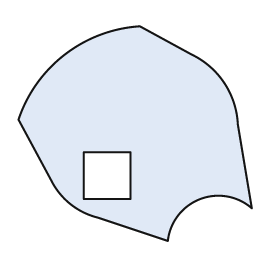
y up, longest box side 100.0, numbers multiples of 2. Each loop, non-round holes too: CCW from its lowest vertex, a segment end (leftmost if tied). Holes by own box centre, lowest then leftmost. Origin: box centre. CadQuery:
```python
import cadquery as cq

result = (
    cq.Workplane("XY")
    .moveTo(14.0, -46.0)
    .threePointArc((28.0, -28.0), (50.0, -32.0))
    .lineTo(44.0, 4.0)
    .threePointArc((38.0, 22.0), (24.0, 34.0))
    .lineTo(2.0, 46.0)
    .threePointArc((-30.0, 34.0), (-50.0, 6.0))
    .lineTo(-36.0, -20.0)
    .threePointArc((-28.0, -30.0), (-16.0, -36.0))
    .close()
    .moveTo(-22.0, -28.0)
    .lineTo(-2.0, -28.0)
    .lineTo(-2.0, -8.0)
    .lineTo(-22.0, -8.0)
    .close()
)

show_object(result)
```